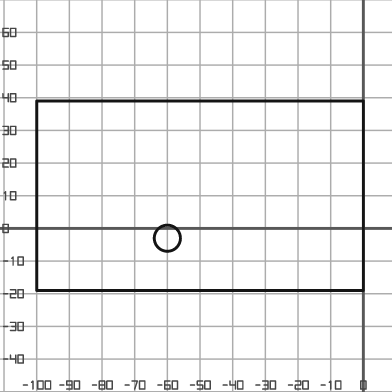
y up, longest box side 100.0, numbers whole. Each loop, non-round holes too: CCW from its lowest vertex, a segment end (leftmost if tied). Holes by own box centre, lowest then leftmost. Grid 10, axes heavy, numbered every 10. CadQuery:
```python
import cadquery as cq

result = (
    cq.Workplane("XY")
    .moveTo(-100.0, -19.0)
    .lineTo(0.0, -19.0)
    .lineTo(0.0, 39.0)
    .lineTo(-100.0, 39.0)
    .close()
    .moveTo(-60.0, -3.0)
    .circle(4.0)
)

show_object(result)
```